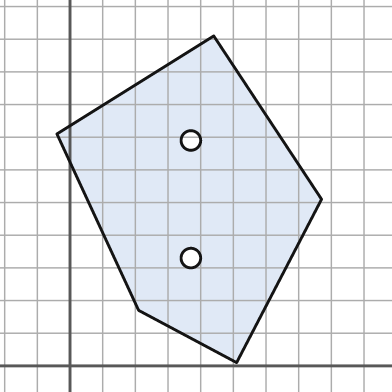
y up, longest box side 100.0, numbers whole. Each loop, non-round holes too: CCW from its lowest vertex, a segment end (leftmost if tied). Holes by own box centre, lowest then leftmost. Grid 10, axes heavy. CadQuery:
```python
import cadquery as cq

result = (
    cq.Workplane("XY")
    .moveTo(51.0, 1.0)
    .lineTo(77.0, 51.0)
    .lineTo(44.0, 101.0)
    .lineTo(-4.0, 71.0)
    .lineTo(21.0, 17.0)
    .close()
    .moveTo(37.0, 33.0)
    .circle(3.0)
    .moveTo(37.0, 69.0)
    .circle(3.0)
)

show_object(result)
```